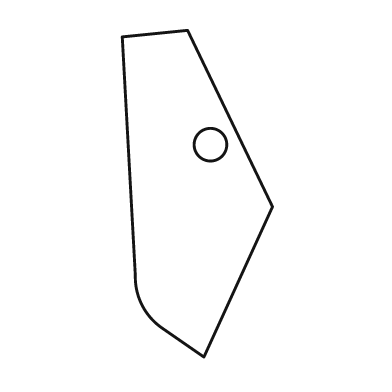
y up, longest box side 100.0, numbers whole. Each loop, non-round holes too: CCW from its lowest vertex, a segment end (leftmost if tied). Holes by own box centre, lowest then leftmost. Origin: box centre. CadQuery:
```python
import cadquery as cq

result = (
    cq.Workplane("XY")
    .moveTo(2.0, -50.0)
    .lineTo(23.0, -4.0)
    .lineTo(-3.0, 50.0)
    .lineTo(-23.0, 48.0)
    .lineTo(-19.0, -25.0)
    .threePointArc((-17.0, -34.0), (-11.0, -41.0))
    .close()
    .moveTo(4.0, 15.0)
    .circle(5.0)
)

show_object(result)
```